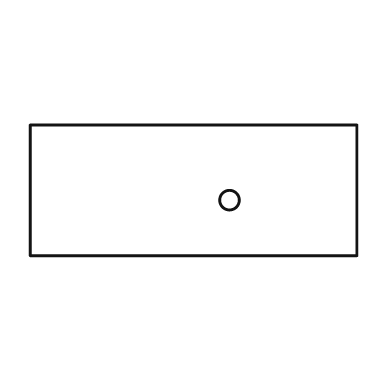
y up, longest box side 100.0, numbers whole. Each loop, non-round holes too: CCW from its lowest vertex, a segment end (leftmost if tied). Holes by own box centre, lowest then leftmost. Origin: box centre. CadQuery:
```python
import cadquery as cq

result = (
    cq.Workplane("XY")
    .moveTo(-50.0, -20.0)
    .lineTo(50.0, -20.0)
    .lineTo(50.0, 20.0)
    .lineTo(-50.0, 20.0)
    .close()
    .moveTo(11.0, -3.0)
    .circle(3.0)
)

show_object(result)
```